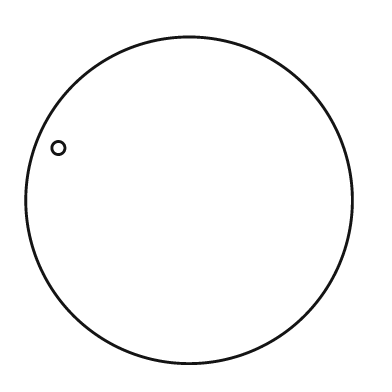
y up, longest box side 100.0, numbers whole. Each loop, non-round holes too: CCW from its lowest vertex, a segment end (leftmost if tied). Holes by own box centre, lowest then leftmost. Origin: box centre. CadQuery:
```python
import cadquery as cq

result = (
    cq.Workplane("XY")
    .moveTo(0.0, 0.0)
    .circle(50.0)
    .moveTo(-40.0, 16.0)
    .circle(2.0)
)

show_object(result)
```